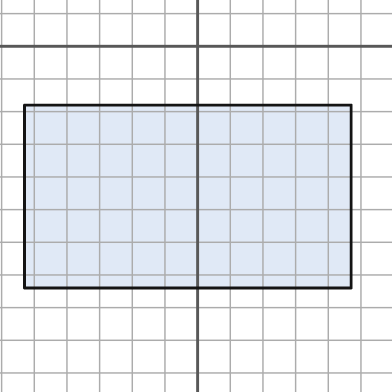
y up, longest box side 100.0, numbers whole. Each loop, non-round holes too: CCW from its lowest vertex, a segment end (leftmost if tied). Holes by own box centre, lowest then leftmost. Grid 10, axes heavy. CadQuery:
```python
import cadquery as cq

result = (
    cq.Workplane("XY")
    .moveTo(-53.0, -74.0)
    .lineTo(47.0, -74.0)
    .lineTo(47.0, -18.0)
    .lineTo(-53.0, -18.0)
    .close()
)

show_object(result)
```